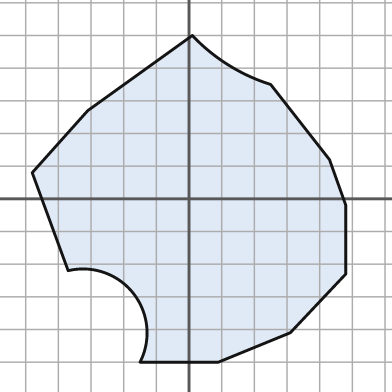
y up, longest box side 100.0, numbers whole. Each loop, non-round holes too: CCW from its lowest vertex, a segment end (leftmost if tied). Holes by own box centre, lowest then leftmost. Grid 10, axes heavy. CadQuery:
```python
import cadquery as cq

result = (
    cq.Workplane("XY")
    .moveTo(-15.0, -50.0)
    .lineTo(9.0, -50.0)
    .lineTo(31.0, -41.0)
    .lineTo(48.0, -23.0)
    .lineTo(48.0, -2.0)
    .lineTo(43.0, 12.0)
    .lineTo(25.0, 35.0)
    .threePointArc((12.0, 41.0), (1.0, 50.0))
    .lineTo(-31.0, 27.0)
    .lineTo(-48.0, 8.0)
    .lineTo(-37.0, -22.0)
    .threePointArc((-17.0, -29.0), (-15.0, -50.0))
    .close()
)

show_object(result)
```